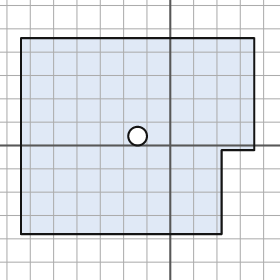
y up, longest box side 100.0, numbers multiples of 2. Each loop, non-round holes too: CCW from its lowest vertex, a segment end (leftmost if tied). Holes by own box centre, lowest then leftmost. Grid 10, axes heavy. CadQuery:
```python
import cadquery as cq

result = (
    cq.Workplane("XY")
    .moveTo(-64.0, -38.0)
    .lineTo(22.0, -38.0)
    .lineTo(22.0, -2.0)
    .lineTo(36.0, -2.0)
    .lineTo(36.0, 46.0)
    .lineTo(-64.0, 46.0)
    .close()
    .moveTo(-14.0, 4.0)
    .circle(4.0)
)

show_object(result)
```